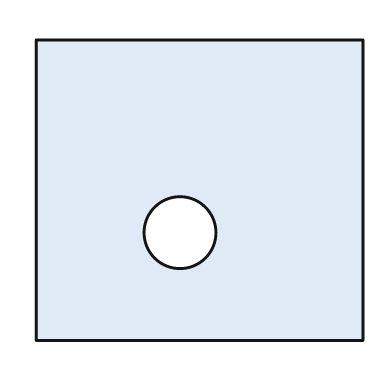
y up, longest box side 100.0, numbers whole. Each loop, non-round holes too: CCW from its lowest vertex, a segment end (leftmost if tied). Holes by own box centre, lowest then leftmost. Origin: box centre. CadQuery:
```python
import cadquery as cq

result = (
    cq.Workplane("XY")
    .moveTo(-50.0, -46.0)
    .lineTo(50.0, -46.0)
    .lineTo(50.0, 46.0)
    .lineTo(-50.0, 46.0)
    .close()
    .moveTo(-6.0, -13.0)
    .circle(11.0)
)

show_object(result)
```